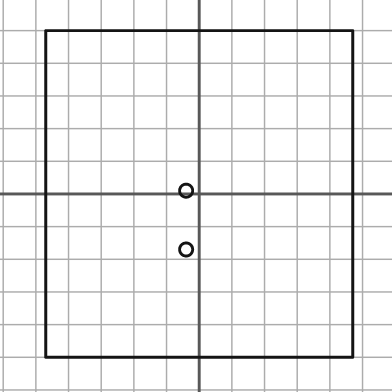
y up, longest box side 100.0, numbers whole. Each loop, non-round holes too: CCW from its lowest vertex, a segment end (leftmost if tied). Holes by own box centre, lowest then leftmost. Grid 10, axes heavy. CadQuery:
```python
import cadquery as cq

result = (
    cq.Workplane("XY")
    .moveTo(-47.0, -50.0)
    .lineTo(47.0, -50.0)
    .lineTo(47.0, 50.0)
    .lineTo(-47.0, 50.0)
    .close()
    .moveTo(-4.0, -17.0)
    .circle(2.0)
    .moveTo(-4.0, 1.0)
    .circle(2.0)
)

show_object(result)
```